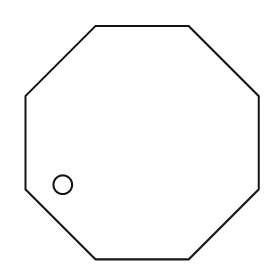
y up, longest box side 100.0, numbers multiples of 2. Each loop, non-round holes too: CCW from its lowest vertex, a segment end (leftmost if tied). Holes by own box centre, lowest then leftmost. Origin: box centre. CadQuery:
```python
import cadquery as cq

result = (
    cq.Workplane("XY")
    .moveTo(-20.0, -50.0)
    .lineTo(20.0, -50.0)
    .lineTo(50.0, -20.0)
    .lineTo(50.0, 20.0)
    .lineTo(20.0, 50.0)
    .lineTo(-20.0, 50.0)
    .lineTo(-50.0, 20.0)
    .lineTo(-50.0, -20.0)
    .close()
    .moveTo(-34.0, -18.0)
    .circle(4.0)
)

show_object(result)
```